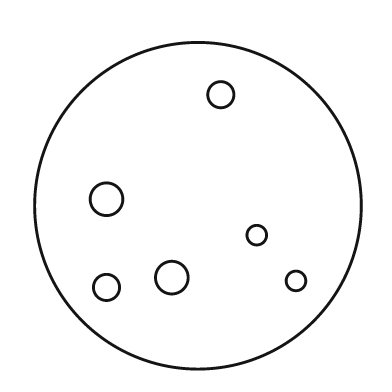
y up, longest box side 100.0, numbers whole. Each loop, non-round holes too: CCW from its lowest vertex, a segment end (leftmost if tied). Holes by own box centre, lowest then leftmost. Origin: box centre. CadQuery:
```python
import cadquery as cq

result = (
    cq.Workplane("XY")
    .moveTo(0.0, 0.0)
    .circle(50.0)
    .moveTo(-28.0, -25.0)
    .circle(4.0)
    .moveTo(30.0, -23.0)
    .circle(3.0)
    .moveTo(-8.0, -22.0)
    .circle(5.0)
    .moveTo(18.0, -9.0)
    .circle(3.0)
    .moveTo(-28.0, 2.0)
    .circle(5.0)
    .moveTo(7.0, 34.0)
    .circle(4.0)
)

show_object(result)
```